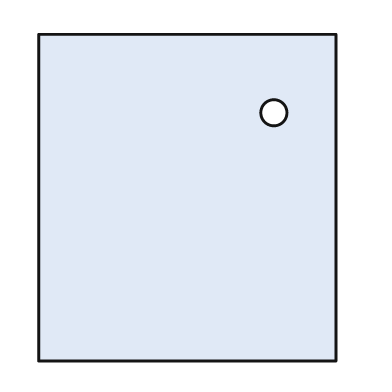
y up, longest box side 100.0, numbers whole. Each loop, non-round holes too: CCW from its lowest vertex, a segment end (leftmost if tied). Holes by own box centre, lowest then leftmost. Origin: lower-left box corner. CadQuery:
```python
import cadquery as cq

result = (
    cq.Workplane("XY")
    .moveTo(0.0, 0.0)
    .lineTo(91.0, 0.0)
    .lineTo(91.0, 100.0)
    .lineTo(0.0, 100.0)
    .close()
    .moveTo(72.0, 76.0)
    .circle(4.0)
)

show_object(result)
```